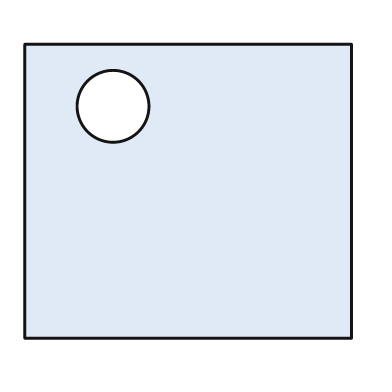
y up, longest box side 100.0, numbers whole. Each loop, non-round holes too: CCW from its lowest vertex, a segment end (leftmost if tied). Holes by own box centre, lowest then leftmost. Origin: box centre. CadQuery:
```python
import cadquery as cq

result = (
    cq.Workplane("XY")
    .moveTo(-50.0, -45.0)
    .lineTo(50.0, -45.0)
    .lineTo(50.0, 45.0)
    .lineTo(-50.0, 45.0)
    .close()
    .moveTo(-23.0, 26.0)
    .circle(11.0)
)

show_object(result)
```